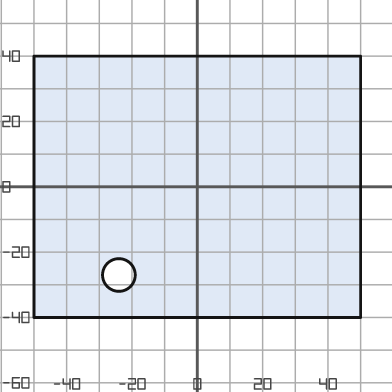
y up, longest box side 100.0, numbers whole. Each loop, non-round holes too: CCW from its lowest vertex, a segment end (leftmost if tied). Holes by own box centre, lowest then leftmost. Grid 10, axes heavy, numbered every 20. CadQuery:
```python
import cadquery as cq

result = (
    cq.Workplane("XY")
    .moveTo(-50.0, -40.0)
    .lineTo(50.0, -40.0)
    .lineTo(50.0, 40.0)
    .lineTo(-50.0, 40.0)
    .close()
    .moveTo(-24.0, -27.0)
    .circle(5.0)
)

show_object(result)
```